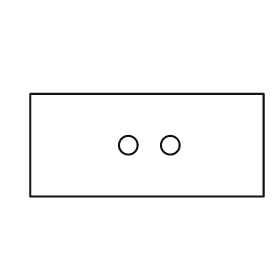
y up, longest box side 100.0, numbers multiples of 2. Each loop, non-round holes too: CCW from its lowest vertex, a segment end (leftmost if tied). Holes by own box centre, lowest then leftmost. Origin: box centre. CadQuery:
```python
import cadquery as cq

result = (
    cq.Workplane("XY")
    .moveTo(-50.0, -22.0)
    .lineTo(50.0, -22.0)
    .lineTo(50.0, 22.0)
    .lineTo(-50.0, 22.0)
    .close()
    .moveTo(-8.0, 0.0)
    .circle(4.0)
    .moveTo(10.0, 0.0)
    .circle(4.0)
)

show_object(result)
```